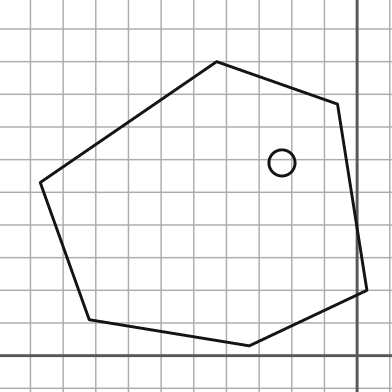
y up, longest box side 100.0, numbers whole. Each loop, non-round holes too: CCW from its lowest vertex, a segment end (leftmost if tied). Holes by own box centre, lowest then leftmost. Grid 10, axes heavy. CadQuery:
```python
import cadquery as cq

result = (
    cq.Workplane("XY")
    .moveTo(-33.0, 3.0)
    .lineTo(3.0, 20.0)
    .lineTo(-6.0, 77.0)
    .lineTo(-43.0, 90.0)
    .lineTo(-97.0, 53.0)
    .lineTo(-82.0, 11.0)
    .close()
    .moveTo(-23.0, 59.0)
    .circle(4.0)
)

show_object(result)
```